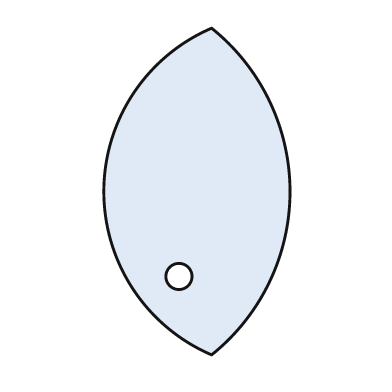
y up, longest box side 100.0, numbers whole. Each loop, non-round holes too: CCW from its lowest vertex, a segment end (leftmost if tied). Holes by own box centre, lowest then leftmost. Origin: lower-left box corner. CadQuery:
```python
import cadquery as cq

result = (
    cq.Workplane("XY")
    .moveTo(33.0, 0.0)
    .threePointArc((57.0, 50.0), (33.0, 100.0))
    .threePointArc((0.0, 50.0), (33.0, 0.0))
    .close()
    .moveTo(23.0, 24.0)
    .circle(4.0)
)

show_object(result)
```